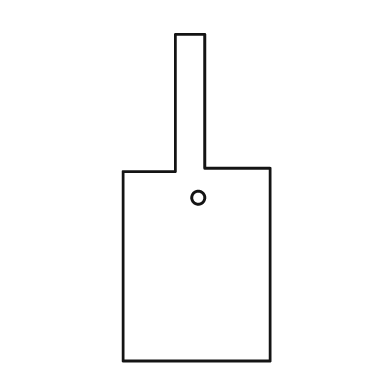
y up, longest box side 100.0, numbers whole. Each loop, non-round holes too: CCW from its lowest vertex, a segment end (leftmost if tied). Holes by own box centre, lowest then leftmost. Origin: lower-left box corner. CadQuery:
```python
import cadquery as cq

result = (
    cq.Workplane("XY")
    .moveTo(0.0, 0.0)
    .lineTo(45.0, 0.0)
    .lineTo(45.0, 59.0)
    .lineTo(25.0, 59.0)
    .lineTo(25.0, 100.0)
    .lineTo(16.0, 100.0)
    .lineTo(16.0, 58.0)
    .lineTo(0.0, 58.0)
    .close()
    .moveTo(23.0, 50.0)
    .circle(2.0)
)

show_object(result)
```